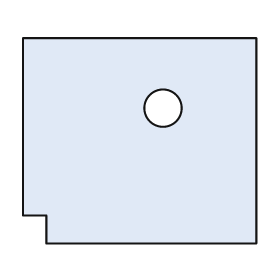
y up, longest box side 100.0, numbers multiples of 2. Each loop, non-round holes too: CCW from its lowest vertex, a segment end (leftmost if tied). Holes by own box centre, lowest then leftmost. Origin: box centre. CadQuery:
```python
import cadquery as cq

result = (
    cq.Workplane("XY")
    .moveTo(-40.0, -44.0)
    .lineTo(50.0, -44.0)
    .lineTo(50.0, 44.0)
    .lineTo(-50.0, 44.0)
    .lineTo(-50.0, -32.0)
    .lineTo(-40.0, -32.0)
    .close()
    .moveTo(10.0, 14.0)
    .circle(8.0)
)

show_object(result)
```